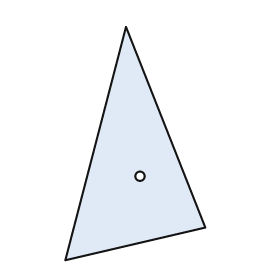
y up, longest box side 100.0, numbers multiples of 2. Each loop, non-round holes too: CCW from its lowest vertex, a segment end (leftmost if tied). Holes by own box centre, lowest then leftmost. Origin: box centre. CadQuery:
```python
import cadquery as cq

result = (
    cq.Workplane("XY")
    .moveTo(-30.0, -50.0)
    .lineTo(30.0, -36.0)
    .lineTo(-4.0, 50.0)
    .close()
    .moveTo(2.0, -14.0)
    .circle(2.0)
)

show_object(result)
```